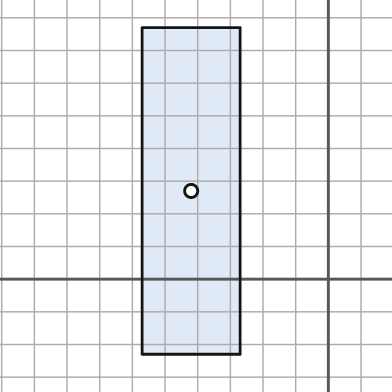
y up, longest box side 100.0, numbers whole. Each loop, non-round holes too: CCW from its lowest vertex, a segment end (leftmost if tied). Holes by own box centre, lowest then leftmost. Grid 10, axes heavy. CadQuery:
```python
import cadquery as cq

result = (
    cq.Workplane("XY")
    .moveTo(-57.0, -23.0)
    .lineTo(-27.0, -23.0)
    .lineTo(-27.0, 77.0)
    .lineTo(-57.0, 77.0)
    .close()
    .moveTo(-42.0, 27.0)
    .circle(2.0)
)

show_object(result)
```